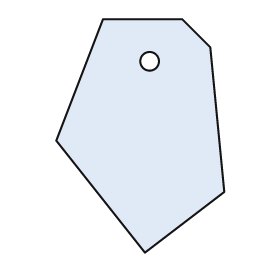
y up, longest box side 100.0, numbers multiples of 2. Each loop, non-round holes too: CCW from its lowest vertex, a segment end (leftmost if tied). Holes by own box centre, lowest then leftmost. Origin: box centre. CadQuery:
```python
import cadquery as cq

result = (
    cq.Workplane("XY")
    .moveTo(2.0, -50.0)
    .lineTo(36.0, -24.0)
    .lineTo(30.0, 38.0)
    .lineTo(18.0, 50.0)
    .lineTo(-16.0, 50.0)
    .lineTo(-36.0, -2.0)
    .close()
    .moveTo(4.0, 32.0)
    .circle(4.0)
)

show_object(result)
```